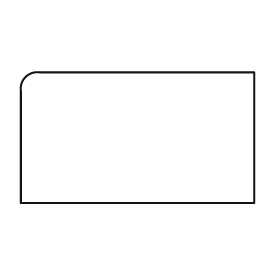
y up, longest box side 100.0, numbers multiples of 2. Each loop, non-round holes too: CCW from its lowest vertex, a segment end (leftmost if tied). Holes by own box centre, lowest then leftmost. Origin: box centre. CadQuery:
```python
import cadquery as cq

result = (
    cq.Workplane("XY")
    .moveTo(-50.0, -28.0)
    .lineTo(50.0, -28.0)
    .lineTo(50.0, 28.0)
    .lineTo(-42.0, 28.0)
    .threePointArc((-48.0, 26.0), (-50.0, 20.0))
    .close()
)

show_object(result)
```